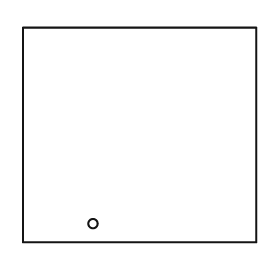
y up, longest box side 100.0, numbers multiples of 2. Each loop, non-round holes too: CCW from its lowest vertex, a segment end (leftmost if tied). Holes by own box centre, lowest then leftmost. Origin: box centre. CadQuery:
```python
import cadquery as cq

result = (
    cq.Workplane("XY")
    .moveTo(-50.0, -46.0)
    .lineTo(50.0, -46.0)
    .lineTo(50.0, 46.0)
    .lineTo(-50.0, 46.0)
    .close()
    .moveTo(-20.0, -38.0)
    .circle(2.0)
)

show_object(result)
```